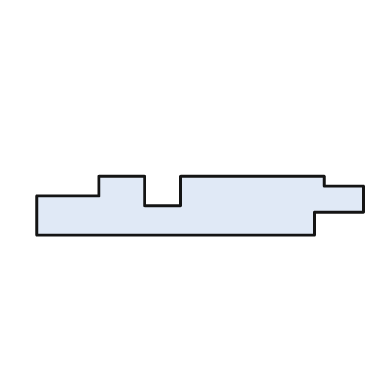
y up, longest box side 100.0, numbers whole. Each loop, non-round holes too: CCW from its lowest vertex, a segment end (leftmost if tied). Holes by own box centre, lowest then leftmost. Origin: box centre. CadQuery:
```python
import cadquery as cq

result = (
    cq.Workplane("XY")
    .moveTo(-50.0, -9.0)
    .lineTo(35.0, -9.0)
    .lineTo(35.0, -2.0)
    .lineTo(50.0, -2.0)
    .lineTo(50.0, 6.0)
    .lineTo(38.0, 6.0)
    .lineTo(38.0, 9.0)
    .lineTo(-6.0, 9.0)
    .lineTo(-6.0, 0.0)
    .lineTo(-17.0, 0.0)
    .lineTo(-17.0, 9.0)
    .lineTo(-31.0, 9.0)
    .lineTo(-31.0, 3.0)
    .lineTo(-50.0, 3.0)
    .close()
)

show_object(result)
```